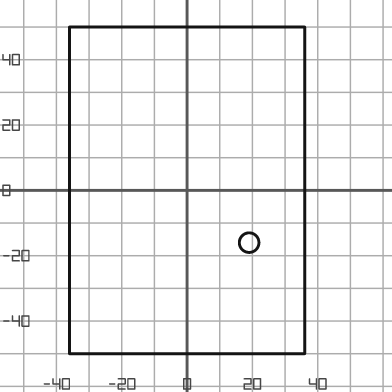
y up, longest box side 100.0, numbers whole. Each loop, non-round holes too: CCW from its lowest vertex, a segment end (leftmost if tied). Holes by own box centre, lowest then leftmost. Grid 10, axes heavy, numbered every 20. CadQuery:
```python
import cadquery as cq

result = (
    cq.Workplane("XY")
    .moveTo(-36.0, -50.0)
    .lineTo(36.0, -50.0)
    .lineTo(36.0, 50.0)
    .lineTo(-36.0, 50.0)
    .close()
    .moveTo(19.0, -16.0)
    .circle(3.0)
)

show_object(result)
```